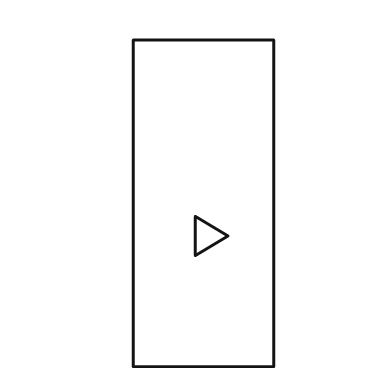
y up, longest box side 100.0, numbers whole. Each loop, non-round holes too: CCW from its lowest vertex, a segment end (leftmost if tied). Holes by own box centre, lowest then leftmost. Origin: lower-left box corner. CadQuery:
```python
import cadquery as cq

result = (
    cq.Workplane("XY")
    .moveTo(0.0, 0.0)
    .lineTo(43.0, 0.0)
    .lineTo(43.0, 100.0)
    .lineTo(0.0, 100.0)
    .close()
    .moveTo(19.0, 34.0)
    .lineTo(29.0, 40.0)
    .lineTo(19.0, 46.0)
    .close()
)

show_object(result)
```